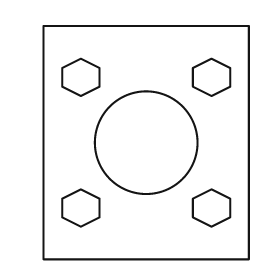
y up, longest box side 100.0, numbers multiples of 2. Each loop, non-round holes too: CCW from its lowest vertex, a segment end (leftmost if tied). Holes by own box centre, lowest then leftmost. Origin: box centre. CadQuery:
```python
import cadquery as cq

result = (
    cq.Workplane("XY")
    .moveTo(-44.0, -50.0)
    .lineTo(44.0, -50.0)
    .lineTo(44.0, 50.0)
    .lineTo(-44.0, 50.0)
    .close()
    .moveTo(-28.0, -36.0)
    .lineTo(-20.0, -32.0)
    .lineTo(-20.0, -24.0)
    .lineTo(-28.0, -20.0)
    .lineTo(-36.0, -24.0)
    .lineTo(-36.0, -32.0)
    .close()
    .moveTo(28.0, -36.0)
    .lineTo(36.0, -32.0)
    .lineTo(36.0, -24.0)
    .lineTo(28.0, -20.0)
    .lineTo(20.0, -24.0)
    .lineTo(20.0, -32.0)
    .close()
    .moveTo(0.0, 0.0)
    .circle(22.0)
    .moveTo(-28.0, 20.0)
    .lineTo(-20.0, 24.0)
    .lineTo(-20.0, 32.0)
    .lineTo(-28.0, 36.0)
    .lineTo(-36.0, 32.0)
    .lineTo(-36.0, 24.0)
    .close()
    .moveTo(28.0, 20.0)
    .lineTo(36.0, 24.0)
    .lineTo(36.0, 32.0)
    .lineTo(28.0, 36.0)
    .lineTo(20.0, 32.0)
    .lineTo(20.0, 24.0)
    .close()
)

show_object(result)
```